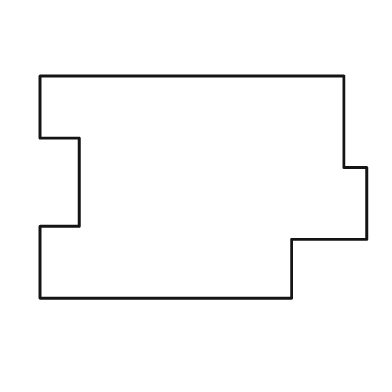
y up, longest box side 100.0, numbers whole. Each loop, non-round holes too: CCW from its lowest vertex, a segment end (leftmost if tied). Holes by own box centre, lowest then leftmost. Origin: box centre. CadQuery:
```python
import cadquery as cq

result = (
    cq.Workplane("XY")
    .moveTo(-50.0, -34.0)
    .lineTo(27.0, -34.0)
    .lineTo(27.0, -16.0)
    .lineTo(50.0, -16.0)
    .lineTo(50.0, 6.0)
    .lineTo(43.0, 6.0)
    .lineTo(43.0, 34.0)
    .lineTo(-50.0, 34.0)
    .lineTo(-50.0, 15.0)
    .lineTo(-38.0, 15.0)
    .lineTo(-38.0, -12.0)
    .lineTo(-50.0, -12.0)
    .close()
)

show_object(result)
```